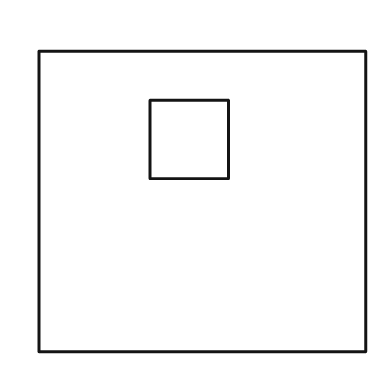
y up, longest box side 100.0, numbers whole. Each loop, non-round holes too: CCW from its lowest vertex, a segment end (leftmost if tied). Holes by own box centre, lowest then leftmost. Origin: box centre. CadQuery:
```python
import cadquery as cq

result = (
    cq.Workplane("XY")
    .moveTo(-50.0, -46.0)
    .lineTo(50.0, -46.0)
    .lineTo(50.0, 46.0)
    .lineTo(-50.0, 46.0)
    .close()
    .moveTo(-16.0, 7.0)
    .lineTo(8.0, 7.0)
    .lineTo(8.0, 31.0)
    .lineTo(-16.0, 31.0)
    .close()
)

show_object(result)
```